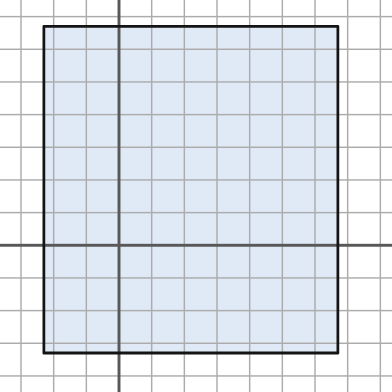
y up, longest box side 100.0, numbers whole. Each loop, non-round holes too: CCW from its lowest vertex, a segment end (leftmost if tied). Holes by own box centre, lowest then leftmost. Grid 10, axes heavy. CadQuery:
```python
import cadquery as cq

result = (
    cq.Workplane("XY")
    .moveTo(-23.0, -33.0)
    .lineTo(67.0, -33.0)
    .lineTo(67.0, 67.0)
    .lineTo(-23.0, 67.0)
    .close()
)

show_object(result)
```